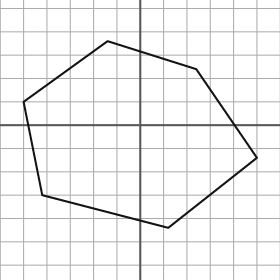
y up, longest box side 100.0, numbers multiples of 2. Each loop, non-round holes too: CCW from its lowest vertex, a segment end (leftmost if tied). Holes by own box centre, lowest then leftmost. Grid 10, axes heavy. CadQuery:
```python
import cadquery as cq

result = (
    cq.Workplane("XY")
    .moveTo(12.0, -44.0)
    .lineTo(50.0, -14.0)
    .lineTo(24.0, 24.0)
    .lineTo(-14.0, 36.0)
    .lineTo(-50.0, 10.0)
    .lineTo(-42.0, -30.0)
    .close()
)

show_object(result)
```